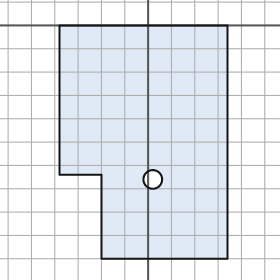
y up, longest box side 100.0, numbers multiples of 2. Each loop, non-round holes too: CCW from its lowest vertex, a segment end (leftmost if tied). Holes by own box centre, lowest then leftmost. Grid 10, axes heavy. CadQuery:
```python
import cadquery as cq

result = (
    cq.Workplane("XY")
    .moveTo(-20.0, -100.0)
    .lineTo(34.0, -100.0)
    .lineTo(34.0, 0.0)
    .lineTo(-38.0, 0.0)
    .lineTo(-38.0, -64.0)
    .lineTo(-20.0, -64.0)
    .close()
    .moveTo(2.0, -66.0)
    .circle(4.0)
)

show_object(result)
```